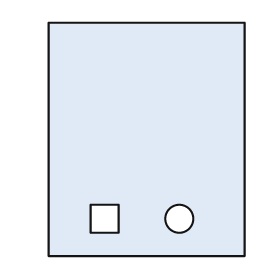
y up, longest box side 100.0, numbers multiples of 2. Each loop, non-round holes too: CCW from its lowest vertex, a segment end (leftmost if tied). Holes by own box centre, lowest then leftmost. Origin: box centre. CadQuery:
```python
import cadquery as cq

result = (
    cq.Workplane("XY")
    .moveTo(-42.0, -50.0)
    .lineTo(42.0, -50.0)
    .lineTo(42.0, 50.0)
    .lineTo(-42.0, 50.0)
    .close()
    .moveTo(-24.0, -40.0)
    .lineTo(-12.0, -40.0)
    .lineTo(-12.0, -28.0)
    .lineTo(-24.0, -28.0)
    .close()
    .moveTo(14.0, -34.0)
    .circle(6.0)
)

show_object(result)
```